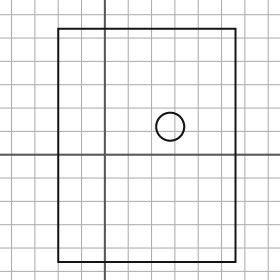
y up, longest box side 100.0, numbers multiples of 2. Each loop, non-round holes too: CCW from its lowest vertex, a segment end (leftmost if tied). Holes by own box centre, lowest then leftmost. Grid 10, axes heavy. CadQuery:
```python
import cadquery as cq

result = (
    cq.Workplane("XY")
    .moveTo(-20.0, -46.0)
    .lineTo(56.0, -46.0)
    .lineTo(56.0, 54.0)
    .lineTo(-20.0, 54.0)
    .close()
    .moveTo(28.0, 12.0)
    .circle(6.0)
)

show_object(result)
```